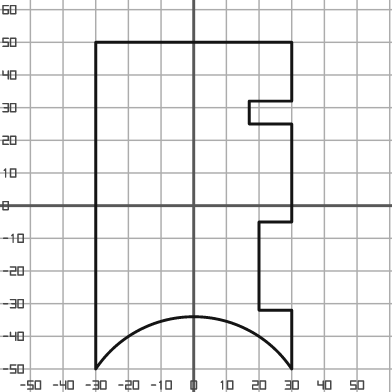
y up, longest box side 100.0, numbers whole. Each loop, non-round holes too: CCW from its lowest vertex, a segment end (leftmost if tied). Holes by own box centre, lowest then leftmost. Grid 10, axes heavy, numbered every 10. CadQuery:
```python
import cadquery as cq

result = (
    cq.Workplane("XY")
    .moveTo(-30.0, -50.0)
    .threePointArc((0.0, -34.0), (30.0, -50.0))
    .lineTo(30.0, -32.0)
    .lineTo(20.0, -32.0)
    .lineTo(20.0, -5.0)
    .lineTo(30.0, -5.0)
    .lineTo(30.0, 25.0)
    .lineTo(17.0, 25.0)
    .lineTo(17.0, 32.0)
    .lineTo(30.0, 32.0)
    .lineTo(30.0, 50.0)
    .lineTo(-30.0, 50.0)
    .close()
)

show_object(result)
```